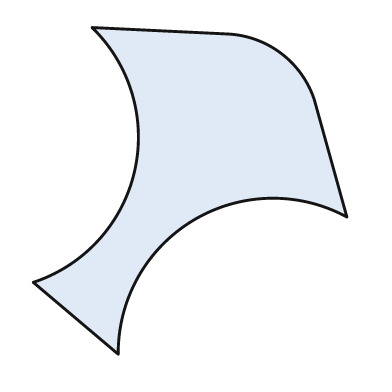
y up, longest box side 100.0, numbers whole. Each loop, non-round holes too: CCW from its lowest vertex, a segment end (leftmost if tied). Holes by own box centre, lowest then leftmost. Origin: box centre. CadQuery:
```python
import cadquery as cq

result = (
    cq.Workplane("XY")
    .moveTo(-22.0, -50.0)
    .threePointArc((1.0, -9.0), (48.0, -8.0))
    .lineTo(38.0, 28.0)
    .threePointArc((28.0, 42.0), (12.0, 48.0))
    .lineTo(-30.0, 50.0)
    .threePointArc((-17.0, 6.0), (-48.0, -28.0))
    .close()
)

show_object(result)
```